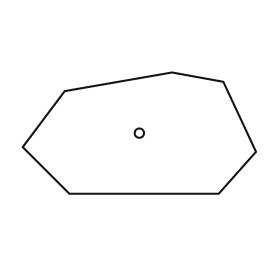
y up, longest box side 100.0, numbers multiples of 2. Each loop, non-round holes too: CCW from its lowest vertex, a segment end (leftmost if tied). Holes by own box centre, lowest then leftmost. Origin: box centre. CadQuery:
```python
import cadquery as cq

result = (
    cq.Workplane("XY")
    .moveTo(-30.0, -26.0)
    .lineTo(34.0, -26.0)
    .lineTo(50.0, -8.0)
    .lineTo(36.0, 22.0)
    .lineTo(14.0, 26.0)
    .lineTo(-32.0, 18.0)
    .lineTo(-50.0, -6.0)
    .close()
    .moveTo(0.0, 0.0)
    .circle(2.0)
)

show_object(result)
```